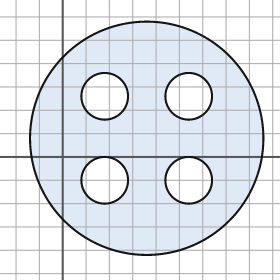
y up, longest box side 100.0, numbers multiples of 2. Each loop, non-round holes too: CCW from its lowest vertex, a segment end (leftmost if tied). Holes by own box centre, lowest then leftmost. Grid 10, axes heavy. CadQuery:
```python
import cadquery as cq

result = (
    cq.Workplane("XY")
    .moveTo(36.0, 8.0)
    .circle(50.0)
    .moveTo(18.0, -10.0)
    .circle(10.0)
    .moveTo(54.0, -10.0)
    .circle(10.0)
    .moveTo(18.0, 26.0)
    .circle(10.0)
    .moveTo(54.0, 26.0)
    .circle(10.0)
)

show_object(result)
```